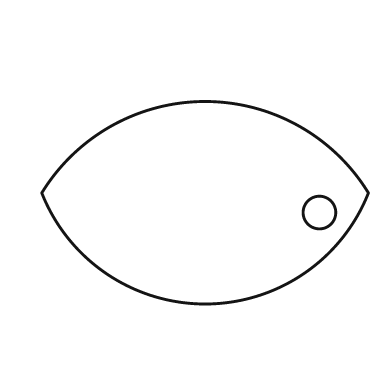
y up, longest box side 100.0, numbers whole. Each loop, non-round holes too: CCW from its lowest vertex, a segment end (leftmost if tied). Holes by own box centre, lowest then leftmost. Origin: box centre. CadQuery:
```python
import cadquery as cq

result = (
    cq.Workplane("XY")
    .moveTo(-50.0, 3.0)
    .threePointArc((0.0, -31.0), (50.0, 3.0))
    .threePointArc((0.0, 31.0), (-50.0, 3.0))
    .close()
    .moveTo(35.0, -3.0)
    .circle(5.0)
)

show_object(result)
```